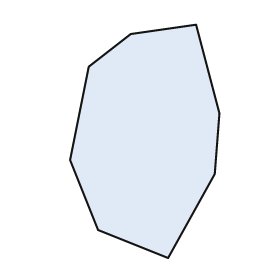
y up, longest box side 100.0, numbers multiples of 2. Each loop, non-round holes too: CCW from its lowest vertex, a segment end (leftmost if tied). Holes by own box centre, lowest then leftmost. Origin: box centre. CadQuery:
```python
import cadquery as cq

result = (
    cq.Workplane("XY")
    .moveTo(10.0, -50.0)
    .lineTo(30.0, -14.0)
    .lineTo(32.0, 12.0)
    .lineTo(22.0, 50.0)
    .lineTo(-6.0, 46.0)
    .lineTo(-24.0, 32.0)
    .lineTo(-32.0, -8.0)
    .lineTo(-20.0, -38.0)
    .close()
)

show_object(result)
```